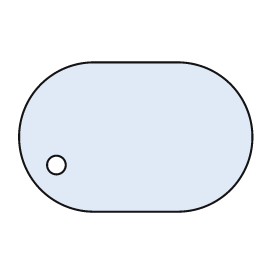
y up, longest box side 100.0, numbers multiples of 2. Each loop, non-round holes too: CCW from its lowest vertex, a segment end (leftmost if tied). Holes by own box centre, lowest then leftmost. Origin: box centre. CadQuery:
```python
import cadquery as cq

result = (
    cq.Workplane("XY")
    .moveTo(-18.0, -32.0)
    .lineTo(18.0, -32.0)
    .threePointArc((50.0, 0.0), (18.0, 32.0))
    .lineTo(-18.0, 32.0)
    .threePointArc((-50.0, 0.0), (-18.0, -32.0))
    .close()
    .moveTo(-34.0, -12.0)
    .circle(4.0)
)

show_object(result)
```